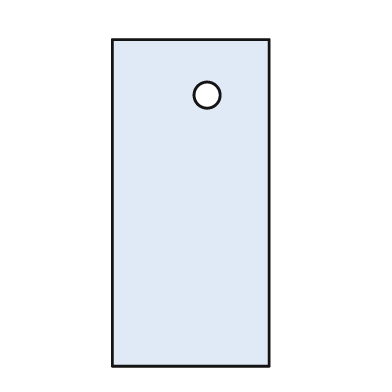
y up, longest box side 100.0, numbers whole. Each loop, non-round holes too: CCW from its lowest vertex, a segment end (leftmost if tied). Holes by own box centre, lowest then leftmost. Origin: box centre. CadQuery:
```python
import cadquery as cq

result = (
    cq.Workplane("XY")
    .moveTo(-24.0, -50.0)
    .lineTo(24.0, -50.0)
    .lineTo(24.0, 50.0)
    .lineTo(-24.0, 50.0)
    .close()
    .moveTo(5.0, 33.0)
    .circle(4.0)
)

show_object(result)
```